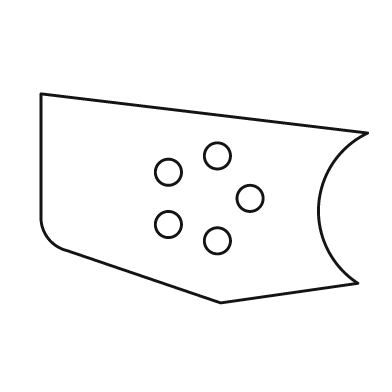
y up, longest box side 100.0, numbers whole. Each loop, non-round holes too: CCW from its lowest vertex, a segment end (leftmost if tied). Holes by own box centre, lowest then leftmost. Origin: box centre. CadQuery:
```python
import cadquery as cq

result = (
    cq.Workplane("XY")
    .moveTo(5.0, -32.0)
    .lineTo(47.0, -26.0)
    .threePointArc((35.0, -2.0), (50.0, 20.0))
    .lineTo(-50.0, 32.0)
    .lineTo(-50.0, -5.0)
    .threePointArc((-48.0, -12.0), (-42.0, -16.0))
    .close()
    .moveTo(4.0, -13.0)
    .circle(4.0)
    .moveTo(-11.0, -8.0)
    .circle(4.0)
    .moveTo(14.0, 0.0)
    .circle(4.0)
    .moveTo(-11.0, 8.0)
    .circle(4.0)
    .moveTo(4.0, 13.0)
    .circle(4.0)
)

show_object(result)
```